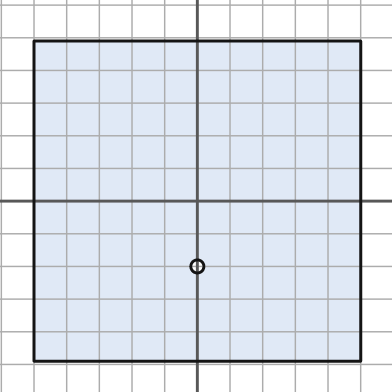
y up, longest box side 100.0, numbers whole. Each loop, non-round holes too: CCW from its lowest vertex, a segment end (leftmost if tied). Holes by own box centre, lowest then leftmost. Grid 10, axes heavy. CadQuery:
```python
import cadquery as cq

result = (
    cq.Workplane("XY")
    .moveTo(-50.0, -49.0)
    .lineTo(50.0, -49.0)
    .lineTo(50.0, 49.0)
    .lineTo(-50.0, 49.0)
    .close()
    .moveTo(0.0, -20.0)
    .circle(2.0)
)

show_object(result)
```